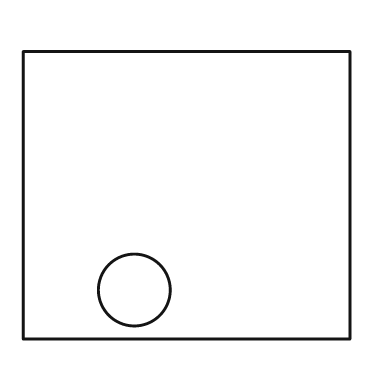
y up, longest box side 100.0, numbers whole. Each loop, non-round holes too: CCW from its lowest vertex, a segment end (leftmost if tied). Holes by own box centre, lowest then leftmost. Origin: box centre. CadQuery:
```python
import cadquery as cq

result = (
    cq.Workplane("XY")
    .moveTo(-50.0, -44.0)
    .lineTo(50.0, -44.0)
    .lineTo(50.0, 44.0)
    .lineTo(-50.0, 44.0)
    .close()
    .moveTo(-16.0, -29.0)
    .circle(11.0)
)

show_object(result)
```